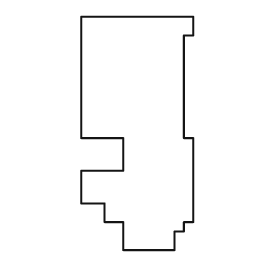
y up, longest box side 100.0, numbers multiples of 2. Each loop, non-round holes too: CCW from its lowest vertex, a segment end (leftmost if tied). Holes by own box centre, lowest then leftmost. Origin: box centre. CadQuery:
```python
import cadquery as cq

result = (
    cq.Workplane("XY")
    .moveTo(-6.0, -50.0)
    .lineTo(16.0, -50.0)
    .lineTo(16.0, -42.0)
    .lineTo(20.0, -42.0)
    .lineTo(20.0, -38.0)
    .lineTo(24.0, -38.0)
    .lineTo(24.0, -2.0)
    .lineTo(20.0, -2.0)
    .lineTo(20.0, 42.0)
    .lineTo(24.0, 42.0)
    .lineTo(24.0, 50.0)
    .lineTo(-24.0, 50.0)
    .lineTo(-24.0, -2.0)
    .lineTo(-6.0, -2.0)
    .lineTo(-6.0, -16.0)
    .lineTo(-24.0, -16.0)
    .lineTo(-24.0, -30.0)
    .lineTo(-14.0, -30.0)
    .lineTo(-14.0, -38.0)
    .lineTo(-6.0, -38.0)
    .close()
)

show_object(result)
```